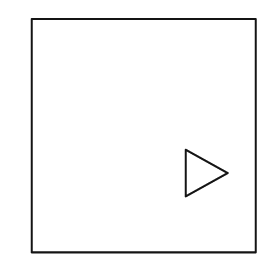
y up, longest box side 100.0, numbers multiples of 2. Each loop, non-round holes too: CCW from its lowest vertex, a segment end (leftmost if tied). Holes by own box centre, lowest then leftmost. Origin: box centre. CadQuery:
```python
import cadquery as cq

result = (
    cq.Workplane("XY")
    .moveTo(-48.0, -50.0)
    .lineTo(48.0, -50.0)
    .lineTo(48.0, 50.0)
    .lineTo(-48.0, 50.0)
    .close()
    .moveTo(18.0, -26.0)
    .lineTo(36.0, -16.0)
    .lineTo(18.0, -6.0)
    .close()
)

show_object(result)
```